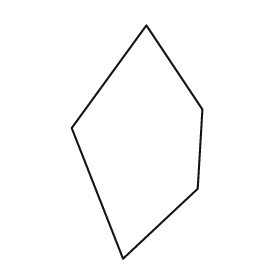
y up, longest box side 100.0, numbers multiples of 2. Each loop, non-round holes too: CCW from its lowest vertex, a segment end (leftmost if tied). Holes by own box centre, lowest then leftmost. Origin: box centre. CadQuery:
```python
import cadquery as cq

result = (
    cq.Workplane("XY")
    .moveTo(-6.0, -50.0)
    .lineTo(26.0, -20.0)
    .lineTo(28.0, 14.0)
    .lineTo(4.0, 50.0)
    .lineTo(-28.0, 6.0)
    .close()
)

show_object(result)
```